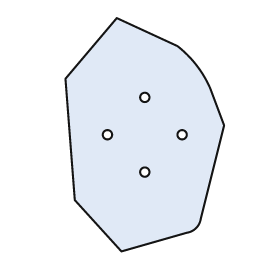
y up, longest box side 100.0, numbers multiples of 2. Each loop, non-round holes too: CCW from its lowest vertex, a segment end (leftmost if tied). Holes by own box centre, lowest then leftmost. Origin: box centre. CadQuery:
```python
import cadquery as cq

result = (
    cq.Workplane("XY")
    .moveTo(-10.0, -50.0)
    .lineTo(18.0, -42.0)
    .threePointArc((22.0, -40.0), (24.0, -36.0))
    .lineTo(34.0, 4.0)
    .lineTo(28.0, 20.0)
    .threePointArc((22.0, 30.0), (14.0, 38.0))
    .lineTo(-12.0, 50.0)
    .lineTo(-34.0, 24.0)
    .lineTo(-30.0, -28.0)
    .close()
    .moveTo(0.0, -16.0)
    .circle(2.0)
    .moveTo(-16.0, 0.0)
    .circle(2.0)
    .moveTo(16.0, 0.0)
    .circle(2.0)
    .moveTo(0.0, 16.0)
    .circle(2.0)
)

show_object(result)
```